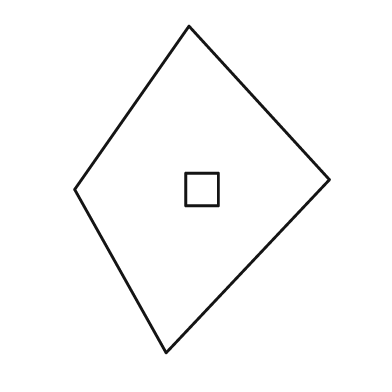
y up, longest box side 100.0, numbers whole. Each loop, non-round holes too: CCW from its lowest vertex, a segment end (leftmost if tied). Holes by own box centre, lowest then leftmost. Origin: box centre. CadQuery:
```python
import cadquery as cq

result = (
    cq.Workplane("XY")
    .moveTo(-11.0, -50.0)
    .lineTo(39.0, 3.0)
    .lineTo(-4.0, 50.0)
    .lineTo(-39.0, 0.0)
    .close()
    .moveTo(-5.0, -5.0)
    .lineTo(5.0, -5.0)
    .lineTo(5.0, 5.0)
    .lineTo(-5.0, 5.0)
    .close()
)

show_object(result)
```